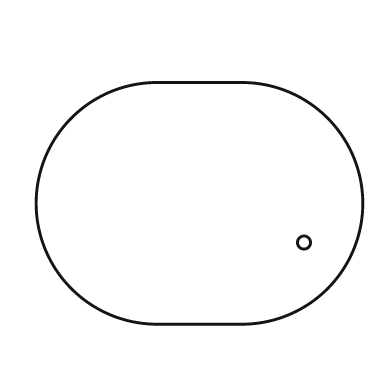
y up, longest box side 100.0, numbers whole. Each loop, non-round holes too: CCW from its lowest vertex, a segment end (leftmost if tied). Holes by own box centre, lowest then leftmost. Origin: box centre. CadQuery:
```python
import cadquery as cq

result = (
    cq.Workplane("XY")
    .moveTo(-13.0, -37.0)
    .lineTo(13.0, -37.0)
    .threePointArc((50.0, 0.0), (13.0, 37.0))
    .lineTo(-13.0, 37.0)
    .threePointArc((-50.0, 0.0), (-13.0, -37.0))
    .close()
    .moveTo(32.0, -12.0)
    .circle(2.0)
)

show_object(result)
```